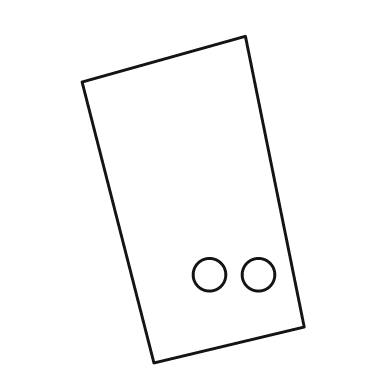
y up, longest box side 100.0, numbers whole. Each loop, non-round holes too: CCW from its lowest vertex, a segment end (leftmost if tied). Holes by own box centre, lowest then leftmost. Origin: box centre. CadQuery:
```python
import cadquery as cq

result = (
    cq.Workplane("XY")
    .moveTo(-12.0, -50.0)
    .lineTo(34.0, -39.0)
    .lineTo(16.0, 50.0)
    .lineTo(-34.0, 36.0)
    .close()
    .moveTo(5.0, -23.0)
    .circle(5.0)
    .moveTo(20.0, -23.0)
    .circle(5.0)
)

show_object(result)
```